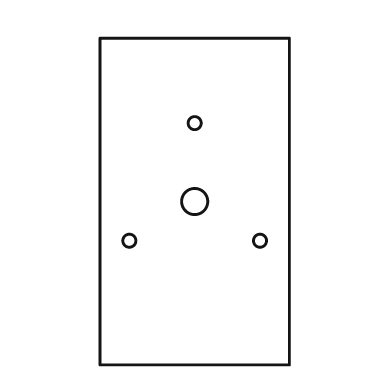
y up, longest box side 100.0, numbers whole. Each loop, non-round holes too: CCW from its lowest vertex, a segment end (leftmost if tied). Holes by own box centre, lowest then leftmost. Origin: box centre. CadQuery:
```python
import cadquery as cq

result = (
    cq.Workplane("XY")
    .moveTo(-29.0, -50.0)
    .lineTo(29.0, -50.0)
    .lineTo(29.0, 50.0)
    .lineTo(-29.0, 50.0)
    .close()
    .moveTo(-20.0, -12.0)
    .circle(2.0)
    .moveTo(20.0, -12.0)
    .circle(2.0)
    .moveTo(0.0, 0.0)
    .circle(4.0)
    .moveTo(0.0, 24.0)
    .circle(2.0)
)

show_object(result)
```